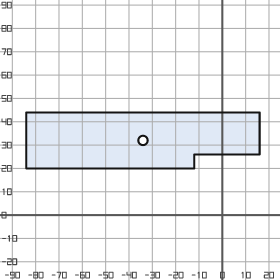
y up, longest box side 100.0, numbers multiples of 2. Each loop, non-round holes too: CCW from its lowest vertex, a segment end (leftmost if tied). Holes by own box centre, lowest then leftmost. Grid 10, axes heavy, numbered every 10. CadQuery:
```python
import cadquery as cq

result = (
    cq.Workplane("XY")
    .moveTo(-84.0, 20.0)
    .lineTo(-12.0, 20.0)
    .lineTo(-12.0, 26.0)
    .lineTo(16.0, 26.0)
    .lineTo(16.0, 44.0)
    .lineTo(-84.0, 44.0)
    .close()
    .moveTo(-34.0, 32.0)
    .circle(2.0)
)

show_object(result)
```